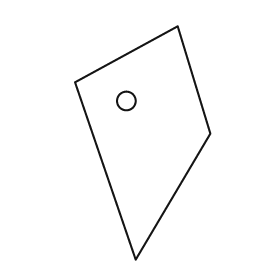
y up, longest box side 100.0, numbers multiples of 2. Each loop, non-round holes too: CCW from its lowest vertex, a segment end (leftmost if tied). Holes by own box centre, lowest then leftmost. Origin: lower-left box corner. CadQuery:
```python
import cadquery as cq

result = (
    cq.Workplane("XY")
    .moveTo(26.0, 0.0)
    .lineTo(58.0, 54.0)
    .lineTo(44.0, 100.0)
    .lineTo(0.0, 76.0)
    .close()
    .moveTo(22.0, 68.0)
    .circle(4.0)
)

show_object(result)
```